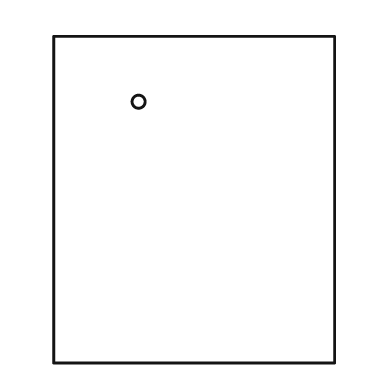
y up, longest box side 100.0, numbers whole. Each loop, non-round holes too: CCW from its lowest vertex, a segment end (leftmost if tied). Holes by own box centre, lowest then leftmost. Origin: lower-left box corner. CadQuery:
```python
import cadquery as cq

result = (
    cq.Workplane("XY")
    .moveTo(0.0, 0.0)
    .lineTo(86.0, 0.0)
    .lineTo(86.0, 100.0)
    .lineTo(0.0, 100.0)
    .close()
    .moveTo(26.0, 80.0)
    .circle(2.0)
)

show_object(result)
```